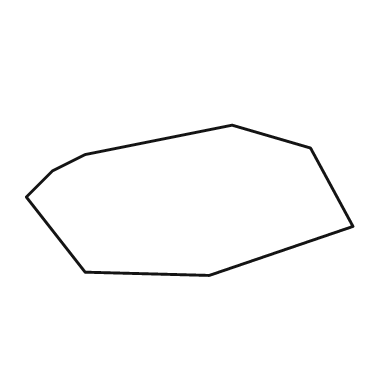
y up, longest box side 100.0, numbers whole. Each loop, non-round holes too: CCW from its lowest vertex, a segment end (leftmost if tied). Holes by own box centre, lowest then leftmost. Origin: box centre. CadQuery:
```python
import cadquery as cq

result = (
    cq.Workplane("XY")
    .moveTo(6.0, -23.0)
    .lineTo(50.0, -8.0)
    .lineTo(37.0, 16.0)
    .lineTo(13.0, 23.0)
    .lineTo(-32.0, 14.0)
    .lineTo(-42.0, 9.0)
    .lineTo(-50.0, 1.0)
    .lineTo(-32.0, -22.0)
    .close()
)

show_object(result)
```